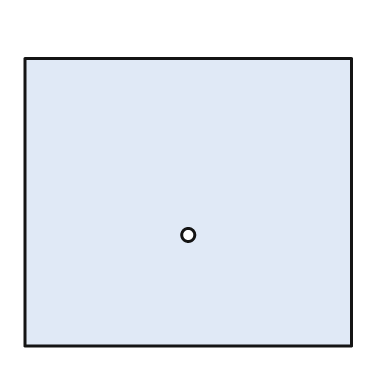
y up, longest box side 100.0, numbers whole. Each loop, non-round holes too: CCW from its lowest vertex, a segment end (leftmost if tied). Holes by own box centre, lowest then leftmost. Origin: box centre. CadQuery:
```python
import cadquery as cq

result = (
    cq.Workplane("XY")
    .moveTo(-50.0, -44.0)
    .lineTo(50.0, -44.0)
    .lineTo(50.0, 44.0)
    .lineTo(-50.0, 44.0)
    .close()
    .moveTo(0.0, -10.0)
    .circle(2.0)
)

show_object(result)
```